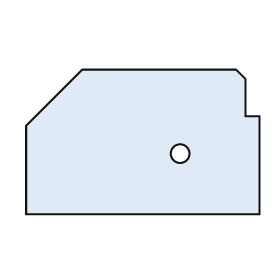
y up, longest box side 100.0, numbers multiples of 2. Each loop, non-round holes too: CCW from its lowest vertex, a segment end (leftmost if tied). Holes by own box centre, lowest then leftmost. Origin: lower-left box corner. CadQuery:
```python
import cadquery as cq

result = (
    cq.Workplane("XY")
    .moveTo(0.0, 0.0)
    .lineTo(100.0, 0.0)
    .lineTo(100.0, 42.0)
    .lineTo(94.0, 42.0)
    .lineTo(94.0, 58.0)
    .lineTo(90.0, 62.0)
    .lineTo(24.0, 62.0)
    .lineTo(0.0, 38.0)
    .close()
    .moveTo(66.0, 26.0)
    .circle(4.0)
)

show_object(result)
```